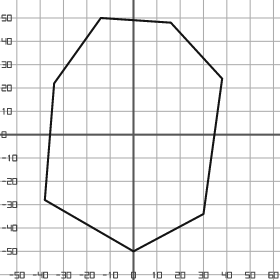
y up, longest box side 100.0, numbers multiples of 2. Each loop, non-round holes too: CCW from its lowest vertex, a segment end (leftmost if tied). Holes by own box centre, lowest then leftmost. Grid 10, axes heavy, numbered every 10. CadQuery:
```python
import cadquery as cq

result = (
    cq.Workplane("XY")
    .moveTo(0.0, -50.0)
    .lineTo(30.0, -34.0)
    .lineTo(38.0, 24.0)
    .lineTo(16.0, 48.0)
    .lineTo(-14.0, 50.0)
    .lineTo(-34.0, 22.0)
    .lineTo(-38.0, -28.0)
    .close()
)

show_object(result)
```